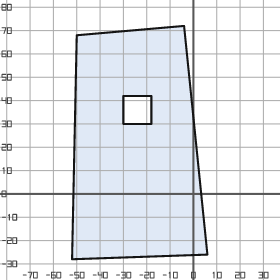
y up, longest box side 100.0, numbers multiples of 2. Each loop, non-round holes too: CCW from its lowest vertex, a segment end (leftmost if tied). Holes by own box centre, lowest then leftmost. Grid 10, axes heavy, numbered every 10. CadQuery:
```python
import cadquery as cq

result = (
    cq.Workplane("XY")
    .moveTo(-52.0, -28.0)
    .lineTo(6.0, -26.0)
    .lineTo(-4.0, 72.0)
    .lineTo(-50.0, 68.0)
    .close()
    .moveTo(-30.0, 30.0)
    .lineTo(-18.0, 30.0)
    .lineTo(-18.0, 42.0)
    .lineTo(-30.0, 42.0)
    .close()
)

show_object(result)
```